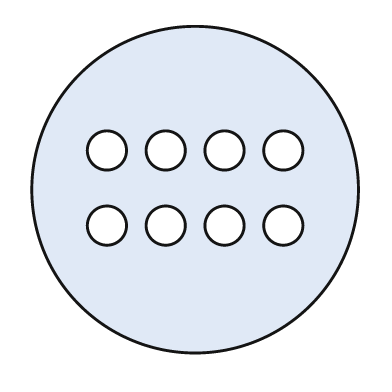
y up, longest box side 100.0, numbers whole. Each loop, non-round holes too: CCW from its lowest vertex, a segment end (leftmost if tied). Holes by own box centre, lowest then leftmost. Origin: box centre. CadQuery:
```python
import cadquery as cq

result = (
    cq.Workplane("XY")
    .moveTo(0.0, 0.0)
    .circle(50.0)
    .moveTo(-27.0, -11.0)
    .circle(6.0)
    .moveTo(-9.0, -11.0)
    .circle(6.0)
    .moveTo(9.0, -11.0)
    .circle(6.0)
    .moveTo(27.0, -11.0)
    .circle(6.0)
    .moveTo(-27.0, 12.0)
    .circle(6.0)
    .moveTo(-9.0, 12.0)
    .circle(6.0)
    .moveTo(9.0, 12.0)
    .circle(6.0)
    .moveTo(27.0, 12.0)
    .circle(6.0)
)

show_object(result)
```